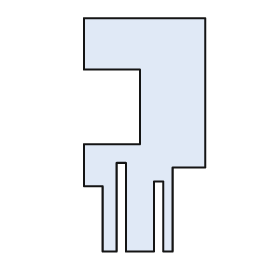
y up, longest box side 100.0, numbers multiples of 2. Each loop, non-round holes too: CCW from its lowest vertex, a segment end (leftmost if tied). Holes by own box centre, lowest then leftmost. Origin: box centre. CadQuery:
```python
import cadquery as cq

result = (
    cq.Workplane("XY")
    .moveTo(-18.0, -50.0)
    .lineTo(-12.0, -50.0)
    .lineTo(-12.0, -12.0)
    .lineTo(-8.0, -12.0)
    .lineTo(-8.0, -50.0)
    .lineTo(4.0, -50.0)
    .lineTo(4.0, -20.0)
    .lineTo(8.0, -20.0)
    .lineTo(8.0, -50.0)
    .lineTo(12.0, -50.0)
    .lineTo(12.0, -14.0)
    .lineTo(26.0, -14.0)
    .lineTo(26.0, 50.0)
    .lineTo(-26.0, 50.0)
    .lineTo(-26.0, 28.0)
    .lineTo(-2.0, 28.0)
    .lineTo(-2.0, -4.0)
    .lineTo(-26.0, -4.0)
    .lineTo(-26.0, -22.0)
    .lineTo(-18.0, -22.0)
    .close()
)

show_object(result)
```